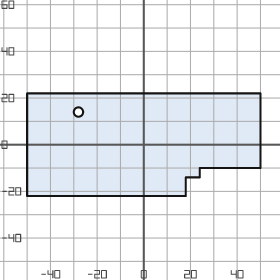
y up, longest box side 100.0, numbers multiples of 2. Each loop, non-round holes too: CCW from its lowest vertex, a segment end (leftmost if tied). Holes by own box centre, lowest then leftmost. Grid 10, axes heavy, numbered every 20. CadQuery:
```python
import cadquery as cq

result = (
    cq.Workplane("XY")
    .moveTo(-50.0, -22.0)
    .lineTo(18.0, -22.0)
    .lineTo(18.0, -14.0)
    .lineTo(24.0, -14.0)
    .lineTo(24.0, -10.0)
    .lineTo(50.0, -10.0)
    .lineTo(50.0, 22.0)
    .lineTo(-50.0, 22.0)
    .close()
    .moveTo(-28.0, 14.0)
    .circle(2.0)
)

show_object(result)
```